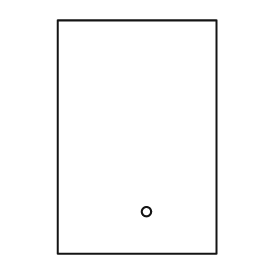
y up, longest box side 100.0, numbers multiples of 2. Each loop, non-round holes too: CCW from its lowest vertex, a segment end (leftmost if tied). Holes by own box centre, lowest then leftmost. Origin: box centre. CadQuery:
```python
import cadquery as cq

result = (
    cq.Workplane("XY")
    .moveTo(-34.0, -50.0)
    .lineTo(34.0, -50.0)
    .lineTo(34.0, 50.0)
    .lineTo(-34.0, 50.0)
    .close()
    .moveTo(4.0, -32.0)
    .circle(2.0)
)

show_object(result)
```